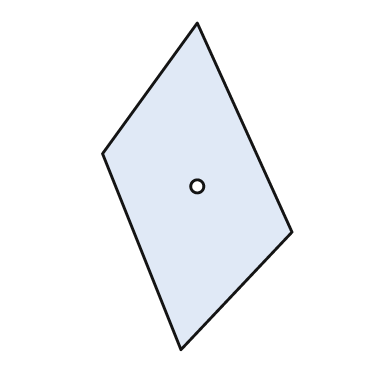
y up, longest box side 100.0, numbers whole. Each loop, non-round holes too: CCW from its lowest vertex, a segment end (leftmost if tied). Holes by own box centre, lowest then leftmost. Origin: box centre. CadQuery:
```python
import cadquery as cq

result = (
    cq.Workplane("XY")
    .moveTo(-5.0, -50.0)
    .lineTo(29.0, -14.0)
    .lineTo(0.0, 50.0)
    .lineTo(-29.0, 10.0)
    .close()
    .moveTo(0.0, 0.0)
    .circle(2.0)
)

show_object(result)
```